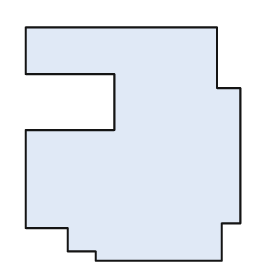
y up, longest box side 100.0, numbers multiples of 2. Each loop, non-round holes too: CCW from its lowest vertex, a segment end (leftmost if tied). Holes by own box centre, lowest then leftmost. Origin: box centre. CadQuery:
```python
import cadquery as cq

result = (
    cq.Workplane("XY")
    .moveTo(-16.0, -50.0)
    .lineTo(38.0, -50.0)
    .lineTo(38.0, -34.0)
    .lineTo(46.0, -34.0)
    .lineTo(46.0, 24.0)
    .lineTo(36.0, 24.0)
    .lineTo(36.0, 50.0)
    .lineTo(-46.0, 50.0)
    .lineTo(-46.0, 30.0)
    .lineTo(-8.0, 30.0)
    .lineTo(-8.0, 6.0)
    .lineTo(-46.0, 6.0)
    .lineTo(-46.0, -36.0)
    .lineTo(-28.0, -36.0)
    .lineTo(-28.0, -46.0)
    .lineTo(-16.0, -46.0)
    .close()
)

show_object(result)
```